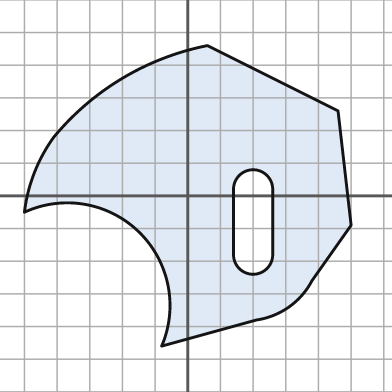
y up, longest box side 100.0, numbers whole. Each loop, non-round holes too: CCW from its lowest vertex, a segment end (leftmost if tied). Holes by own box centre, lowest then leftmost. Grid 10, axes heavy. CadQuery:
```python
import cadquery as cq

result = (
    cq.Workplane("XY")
    .moveTo(-8.0, -46.0)
    .lineTo(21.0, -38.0)
    .threePointArc((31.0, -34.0), (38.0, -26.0))
    .lineTo(50.0, -9.0)
    .lineTo(46.0, 26.0)
    .lineTo(6.0, 46.0)
    .threePointArc((-20.0, 36.0), (-41.0, 18.0))
    .threePointArc((-47.0, 7.0), (-50.0, -5.0))
    .threePointArc((-15.0, -11.0), (-8.0, -46.0))
    .close()
    .moveTo(14.0, -18.0)
    .threePointArc((20.0, -24.0), (26.0, -18.0))
    .lineTo(26.0, 2.0)
    .threePointArc((20.0, 8.0), (14.0, 2.0))
    .close()
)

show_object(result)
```